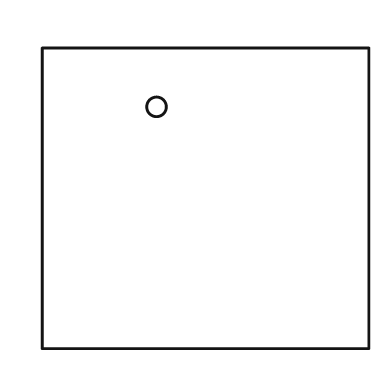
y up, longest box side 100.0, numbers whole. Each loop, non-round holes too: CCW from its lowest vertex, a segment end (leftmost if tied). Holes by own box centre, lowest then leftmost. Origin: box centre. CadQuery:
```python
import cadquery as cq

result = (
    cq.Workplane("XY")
    .moveTo(-50.0, -46.0)
    .lineTo(50.0, -46.0)
    .lineTo(50.0, 46.0)
    .lineTo(-50.0, 46.0)
    .close()
    .moveTo(-15.0, 28.0)
    .circle(3.0)
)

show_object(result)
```